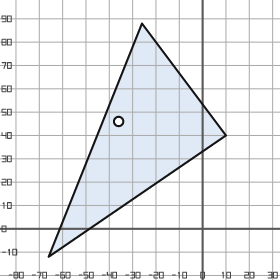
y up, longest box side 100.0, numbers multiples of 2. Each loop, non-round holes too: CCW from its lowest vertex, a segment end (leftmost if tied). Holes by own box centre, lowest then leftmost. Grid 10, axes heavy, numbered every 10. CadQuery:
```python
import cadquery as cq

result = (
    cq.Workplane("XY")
    .moveTo(-66.0, -12.0)
    .lineTo(10.0, 40.0)
    .lineTo(-26.0, 88.0)
    .close()
    .moveTo(-36.0, 46.0)
    .circle(2.0)
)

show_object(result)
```